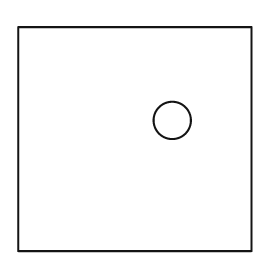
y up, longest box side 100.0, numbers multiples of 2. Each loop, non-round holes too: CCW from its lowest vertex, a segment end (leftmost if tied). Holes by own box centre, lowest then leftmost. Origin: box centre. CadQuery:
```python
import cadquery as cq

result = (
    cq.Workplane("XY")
    .moveTo(-50.0, -48.0)
    .lineTo(50.0, -48.0)
    .lineTo(50.0, 48.0)
    .lineTo(-50.0, 48.0)
    .close()
    .moveTo(16.0, 8.0)
    .circle(8.0)
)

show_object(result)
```